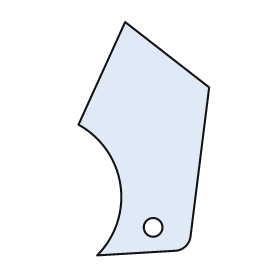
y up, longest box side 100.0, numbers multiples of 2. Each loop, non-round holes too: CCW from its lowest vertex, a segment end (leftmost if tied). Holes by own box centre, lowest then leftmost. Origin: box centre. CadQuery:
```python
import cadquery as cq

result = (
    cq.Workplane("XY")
    .moveTo(-20.0, -50.0)
    .lineTo(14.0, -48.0)
    .threePointArc((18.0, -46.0), (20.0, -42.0))
    .lineTo(28.0, 22.0)
    .lineTo(-8.0, 50.0)
    .lineTo(-28.0, 6.0)
    .threePointArc((-10.0, -20.0), (-20.0, -50.0))
    .close()
    .moveTo(4.0, -38.0)
    .circle(4.0)
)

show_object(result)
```